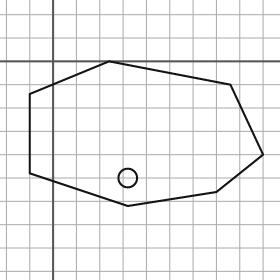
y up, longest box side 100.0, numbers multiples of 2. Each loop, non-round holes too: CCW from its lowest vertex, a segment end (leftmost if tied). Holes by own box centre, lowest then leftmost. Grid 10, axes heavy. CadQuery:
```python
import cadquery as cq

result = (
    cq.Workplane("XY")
    .moveTo(32.0, -62.0)
    .lineTo(70.0, -56.0)
    .lineTo(90.0, -40.0)
    .lineTo(76.0, -10.0)
    .lineTo(24.0, 0.0)
    .lineTo(-10.0, -14.0)
    .lineTo(-10.0, -48.0)
    .close()
    .moveTo(32.0, -50.0)
    .circle(4.0)
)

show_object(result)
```